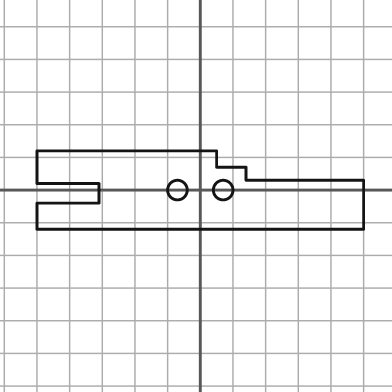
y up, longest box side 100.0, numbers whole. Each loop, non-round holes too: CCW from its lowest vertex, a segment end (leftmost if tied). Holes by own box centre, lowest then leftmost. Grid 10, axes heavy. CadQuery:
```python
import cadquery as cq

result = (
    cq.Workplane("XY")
    .moveTo(-50.0, -12.0)
    .lineTo(50.0, -12.0)
    .lineTo(50.0, 3.0)
    .lineTo(14.0, 3.0)
    .lineTo(14.0, 7.0)
    .lineTo(5.0, 7.0)
    .lineTo(5.0, 12.0)
    .lineTo(-50.0, 12.0)
    .lineTo(-50.0, 2.0)
    .lineTo(-31.0, 2.0)
    .lineTo(-31.0, -4.0)
    .lineTo(-50.0, -4.0)
    .close()
    .moveTo(-7.0, 0.0)
    .circle(3.0)
    .moveTo(7.0, 0.0)
    .circle(3.0)
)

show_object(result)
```